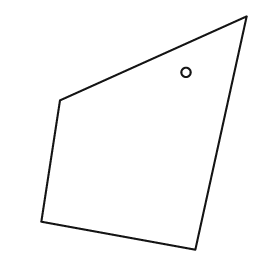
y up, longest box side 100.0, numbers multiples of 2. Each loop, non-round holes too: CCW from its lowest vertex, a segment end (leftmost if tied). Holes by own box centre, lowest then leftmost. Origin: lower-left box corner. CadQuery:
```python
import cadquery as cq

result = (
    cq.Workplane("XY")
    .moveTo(66.0, 0.0)
    .lineTo(88.0, 100.0)
    .lineTo(8.0, 64.0)
    .lineTo(0.0, 12.0)
    .close()
    .moveTo(62.0, 76.0)
    .circle(2.0)
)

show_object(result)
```